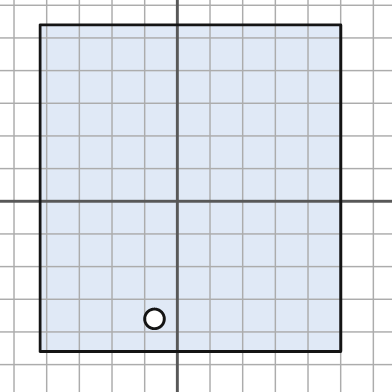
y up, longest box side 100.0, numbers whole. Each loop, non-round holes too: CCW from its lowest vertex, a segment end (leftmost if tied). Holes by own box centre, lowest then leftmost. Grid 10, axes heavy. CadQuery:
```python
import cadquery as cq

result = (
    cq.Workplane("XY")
    .moveTo(-42.0, -46.0)
    .lineTo(50.0, -46.0)
    .lineTo(50.0, 54.0)
    .lineTo(-42.0, 54.0)
    .close()
    .moveTo(-7.0, -36.0)
    .circle(3.0)
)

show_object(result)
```